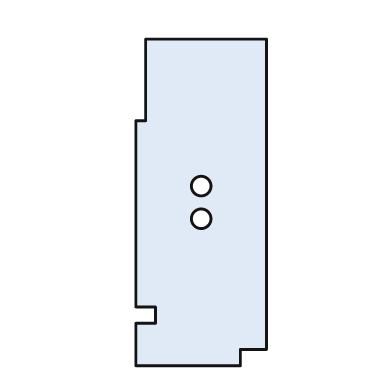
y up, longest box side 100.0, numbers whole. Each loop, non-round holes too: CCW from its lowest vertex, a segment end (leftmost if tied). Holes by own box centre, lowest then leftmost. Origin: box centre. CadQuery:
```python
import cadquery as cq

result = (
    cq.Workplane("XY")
    .moveTo(-20.0, -50.0)
    .lineTo(12.0, -50.0)
    .lineTo(12.0, -45.0)
    .lineTo(20.0, -45.0)
    .lineTo(20.0, 50.0)
    .lineTo(-17.0, 50.0)
    .lineTo(-17.0, 25.0)
    .lineTo(-20.0, 25.0)
    .lineTo(-20.0, -32.0)
    .lineTo(-14.0, -32.0)
    .lineTo(-14.0, -37.0)
    .lineTo(-20.0, -37.0)
    .close()
    .moveTo(0.0, -5.0)
    .circle(3.0)
    .moveTo(0.0, 5.0)
    .circle(3.0)
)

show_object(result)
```